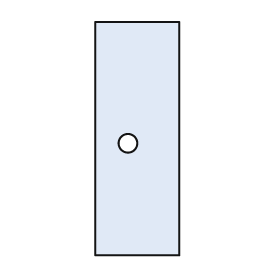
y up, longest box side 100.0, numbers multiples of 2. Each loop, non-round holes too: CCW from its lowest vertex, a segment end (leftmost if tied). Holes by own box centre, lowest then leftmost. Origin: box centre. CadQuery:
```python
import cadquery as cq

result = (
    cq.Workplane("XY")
    .moveTo(-18.0, -50.0)
    .lineTo(18.0, -50.0)
    .lineTo(18.0, 50.0)
    .lineTo(-18.0, 50.0)
    .close()
    .moveTo(-4.0, -2.0)
    .circle(4.0)
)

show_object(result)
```